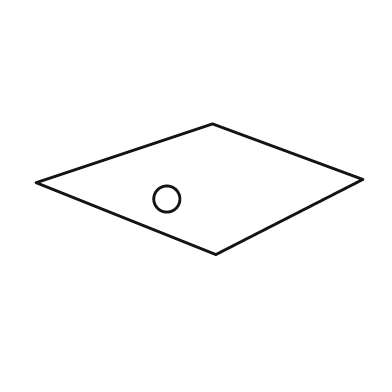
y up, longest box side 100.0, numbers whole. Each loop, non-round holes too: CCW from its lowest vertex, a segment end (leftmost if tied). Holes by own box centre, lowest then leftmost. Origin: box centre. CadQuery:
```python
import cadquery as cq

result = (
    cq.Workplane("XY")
    .moveTo(5.0, -20.0)
    .lineTo(50.0, 3.0)
    .lineTo(4.0, 20.0)
    .lineTo(-50.0, 2.0)
    .close()
    .moveTo(-10.0, -3.0)
    .circle(4.0)
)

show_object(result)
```